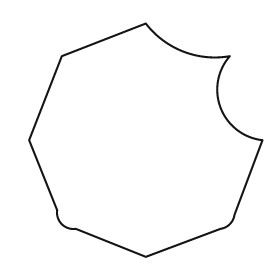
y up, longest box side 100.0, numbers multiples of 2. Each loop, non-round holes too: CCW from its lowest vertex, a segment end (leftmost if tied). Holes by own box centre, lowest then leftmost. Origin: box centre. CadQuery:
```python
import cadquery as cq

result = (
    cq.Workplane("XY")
    .moveTo(0.0, -50.0)
    .lineTo(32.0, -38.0)
    .threePointArc((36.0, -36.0), (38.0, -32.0))
    .lineTo(50.0, 0.0)
    .threePointArc((32.0, 14.0), (36.0, 36.0))
    .threePointArc((16.0, 38.0), (0.0, 50.0))
    .lineTo(-36.0, 36.0)
    .lineTo(-50.0, 0.0)
    .lineTo(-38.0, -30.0)
    .threePointArc((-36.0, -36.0), (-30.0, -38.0))
    .close()
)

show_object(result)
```